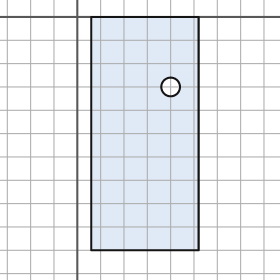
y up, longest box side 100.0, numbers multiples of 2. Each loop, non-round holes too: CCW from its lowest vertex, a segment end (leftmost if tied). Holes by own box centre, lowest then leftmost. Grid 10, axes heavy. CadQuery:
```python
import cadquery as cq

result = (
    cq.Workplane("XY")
    .moveTo(6.0, -100.0)
    .lineTo(52.0, -100.0)
    .lineTo(52.0, 0.0)
    .lineTo(6.0, 0.0)
    .close()
    .moveTo(40.0, -30.0)
    .circle(4.0)
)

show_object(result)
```